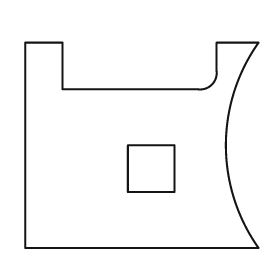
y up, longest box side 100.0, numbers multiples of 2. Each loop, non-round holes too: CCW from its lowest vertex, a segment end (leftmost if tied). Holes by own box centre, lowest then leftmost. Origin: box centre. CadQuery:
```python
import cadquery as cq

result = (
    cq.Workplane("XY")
    .moveTo(-50.0, -44.0)
    .lineTo(50.0, -44.0)
    .threePointArc((36.0, 0.0), (50.0, 44.0))
    .lineTo(32.0, 44.0)
    .lineTo(32.0, 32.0)
    .threePointArc((30.0, 26.0), (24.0, 24.0))
    .lineTo(-34.0, 24.0)
    .lineTo(-34.0, 44.0)
    .lineTo(-50.0, 44.0)
    .close()
    .moveTo(-6.0, -20.0)
    .lineTo(14.0, -20.0)
    .lineTo(14.0, 0.0)
    .lineTo(-6.0, 0.0)
    .close()
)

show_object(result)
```